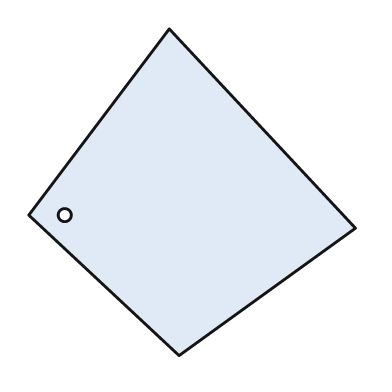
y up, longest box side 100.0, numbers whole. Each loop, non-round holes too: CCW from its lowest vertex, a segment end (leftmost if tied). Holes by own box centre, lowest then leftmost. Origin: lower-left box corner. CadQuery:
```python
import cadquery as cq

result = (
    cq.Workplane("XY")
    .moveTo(46.0, 0.0)
    .lineTo(100.0, 39.0)
    .lineTo(43.0, 100.0)
    .lineTo(0.0, 43.0)
    .close()
    .moveTo(11.0, 43.0)
    .circle(2.0)
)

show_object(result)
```